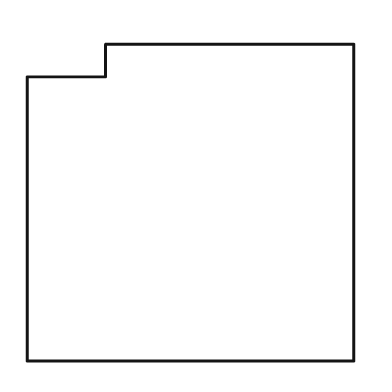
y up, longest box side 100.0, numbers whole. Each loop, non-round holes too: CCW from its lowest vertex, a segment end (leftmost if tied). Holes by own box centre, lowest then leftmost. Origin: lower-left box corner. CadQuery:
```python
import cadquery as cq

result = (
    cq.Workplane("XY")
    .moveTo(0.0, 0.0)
    .lineTo(100.0, 0.0)
    .lineTo(100.0, 97.0)
    .lineTo(24.0, 97.0)
    .lineTo(24.0, 87.0)
    .lineTo(0.0, 87.0)
    .close()
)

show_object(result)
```